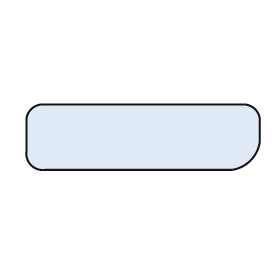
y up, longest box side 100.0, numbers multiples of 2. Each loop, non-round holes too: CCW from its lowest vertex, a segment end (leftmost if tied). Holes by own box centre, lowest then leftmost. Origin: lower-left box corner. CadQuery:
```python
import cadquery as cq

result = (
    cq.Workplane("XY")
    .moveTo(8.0, 0.0)
    .lineTo(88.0, 0.0)
    .threePointArc((96.0, 4.0), (100.0, 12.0))
    .lineTo(100.0, 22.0)
    .threePointArc((98.0, 26.0), (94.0, 28.0))
    .lineTo(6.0, 28.0)
    .threePointArc((2.0, 26.0), (0.0, 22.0))
    .lineTo(0.0, 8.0)
    .threePointArc((2.0, 2.0), (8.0, 0.0))
    .close()
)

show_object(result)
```